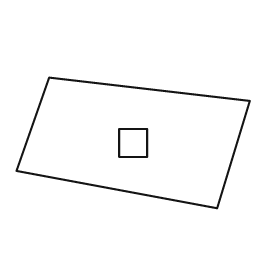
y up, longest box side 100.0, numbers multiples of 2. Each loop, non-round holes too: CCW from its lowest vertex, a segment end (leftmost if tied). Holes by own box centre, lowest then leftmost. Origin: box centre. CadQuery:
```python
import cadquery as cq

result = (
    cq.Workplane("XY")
    .moveTo(36.0, -28.0)
    .lineTo(50.0, 18.0)
    .lineTo(-36.0, 28.0)
    .lineTo(-50.0, -12.0)
    .close()
    .moveTo(-6.0, -6.0)
    .lineTo(6.0, -6.0)
    .lineTo(6.0, 6.0)
    .lineTo(-6.0, 6.0)
    .close()
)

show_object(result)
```